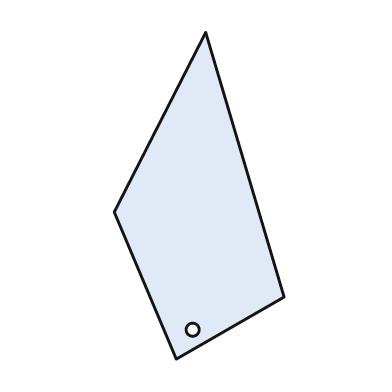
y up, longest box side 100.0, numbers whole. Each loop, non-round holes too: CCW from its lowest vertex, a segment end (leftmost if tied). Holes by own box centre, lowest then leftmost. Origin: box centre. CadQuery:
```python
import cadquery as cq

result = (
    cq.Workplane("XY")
    .moveTo(-7.0, -50.0)
    .lineTo(26.0, -31.0)
    .lineTo(2.0, 50.0)
    .lineTo(-26.0, -5.0)
    .close()
    .moveTo(-2.0, -41.0)
    .circle(2.0)
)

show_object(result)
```